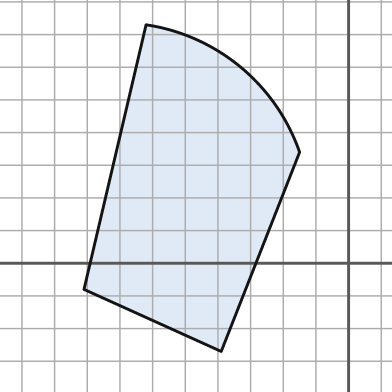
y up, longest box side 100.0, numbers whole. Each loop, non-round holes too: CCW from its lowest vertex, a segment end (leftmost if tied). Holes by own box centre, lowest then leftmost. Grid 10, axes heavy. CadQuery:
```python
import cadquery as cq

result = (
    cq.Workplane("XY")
    .moveTo(-39.0, -27.0)
    .lineTo(-15.0, 34.0)
    .threePointArc((-33.0, 60.0), (-62.0, 73.0))
    .lineTo(-81.0, -8.0)
    .close()
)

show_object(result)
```